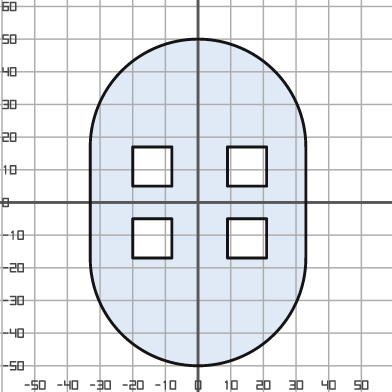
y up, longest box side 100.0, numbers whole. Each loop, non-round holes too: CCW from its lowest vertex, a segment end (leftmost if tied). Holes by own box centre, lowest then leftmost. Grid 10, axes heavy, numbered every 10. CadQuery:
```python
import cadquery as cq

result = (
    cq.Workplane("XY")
    .moveTo(-33.0, -17.0)
    .threePointArc((0.0, -50.0), (33.0, -17.0))
    .lineTo(33.0, 17.0)
    .threePointArc((0.0, 50.0), (-33.0, 17.0))
    .close()
    .moveTo(-20.0, -17.0)
    .lineTo(-8.0, -17.0)
    .lineTo(-8.0, -5.0)
    .lineTo(-20.0, -5.0)
    .close()
    .moveTo(9.0, -17.0)
    .lineTo(21.0, -17.0)
    .lineTo(21.0, -5.0)
    .lineTo(9.0, -5.0)
    .close()
    .moveTo(-20.0, 5.0)
    .lineTo(-8.0, 5.0)
    .lineTo(-8.0, 17.0)
    .lineTo(-20.0, 17.0)
    .close()
    .moveTo(9.0, 5.0)
    .lineTo(21.0, 5.0)
    .lineTo(21.0, 17.0)
    .lineTo(9.0, 17.0)
    .close()
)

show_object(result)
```